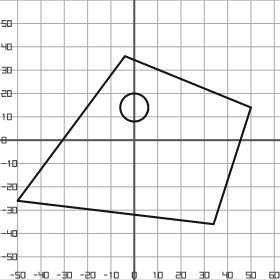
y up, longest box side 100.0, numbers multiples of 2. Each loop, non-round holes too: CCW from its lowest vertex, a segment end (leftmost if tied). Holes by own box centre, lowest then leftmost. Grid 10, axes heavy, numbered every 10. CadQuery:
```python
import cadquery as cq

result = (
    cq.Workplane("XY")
    .moveTo(34.0, -36.0)
    .lineTo(50.0, 14.0)
    .lineTo(-4.0, 36.0)
    .lineTo(-50.0, -26.0)
    .close()
    .moveTo(0.0, 14.0)
    .circle(6.0)
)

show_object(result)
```